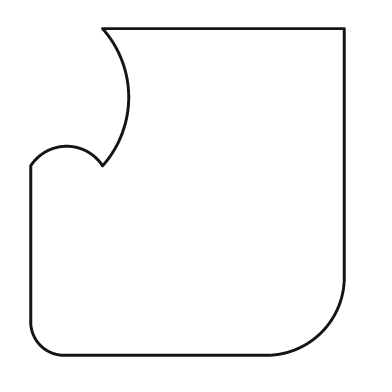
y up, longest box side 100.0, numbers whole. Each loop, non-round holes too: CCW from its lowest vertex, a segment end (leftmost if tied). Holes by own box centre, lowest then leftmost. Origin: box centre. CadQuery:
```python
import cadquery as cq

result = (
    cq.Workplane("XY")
    .moveTo(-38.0, -50.0)
    .lineTo(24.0, -50.0)
    .threePointArc((41.0, -43.0), (48.0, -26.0))
    .lineTo(48.0, 50.0)
    .lineTo(-26.0, 50.0)
    .threePointArc((-18.0, 29.0), (-26.0, 8.0))
    .threePointArc((-37.0, 14.0), (-48.0, 8.0))
    .lineTo(-48.0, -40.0)
    .threePointArc((-45.0, -47.0), (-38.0, -50.0))
    .close()
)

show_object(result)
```